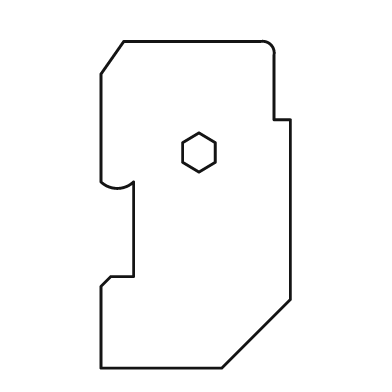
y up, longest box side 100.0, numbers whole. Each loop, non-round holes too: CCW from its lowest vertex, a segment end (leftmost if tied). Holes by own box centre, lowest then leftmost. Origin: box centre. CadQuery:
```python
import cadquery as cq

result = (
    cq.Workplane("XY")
    .moveTo(-29.0, -50.0)
    .lineTo(8.0, -50.0)
    .lineTo(29.0, -29.0)
    .lineTo(29.0, 26.0)
    .lineTo(24.0, 26.0)
    .lineTo(24.0, 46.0)
    .threePointArc((23.0, 49.0), (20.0, 50.0))
    .lineTo(-22.0, 50.0)
    .lineTo(-29.0, 40.0)
    .lineTo(-29.0, 7.0)
    .threePointArc((-24.0, 5.0), (-19.0, 7.0))
    .lineTo(-19.0, -22.0)
    .lineTo(-26.0, -22.0)
    .lineTo(-29.0, -25.0)
    .close()
    .moveTo(1.0, 10.0)
    .lineTo(6.0, 13.0)
    .lineTo(6.0, 19.0)
    .lineTo(1.0, 22.0)
    .lineTo(-4.0, 19.0)
    .lineTo(-4.0, 13.0)
    .close()
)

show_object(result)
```